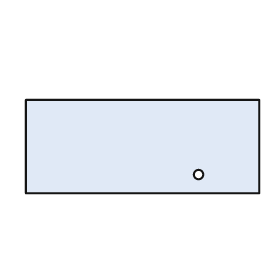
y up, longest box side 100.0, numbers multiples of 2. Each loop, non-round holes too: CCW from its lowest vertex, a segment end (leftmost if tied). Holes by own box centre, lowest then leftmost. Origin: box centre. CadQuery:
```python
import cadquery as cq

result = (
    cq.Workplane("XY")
    .moveTo(-50.0, -20.0)
    .lineTo(50.0, -20.0)
    .lineTo(50.0, 20.0)
    .lineTo(-50.0, 20.0)
    .close()
    .moveTo(24.0, -12.0)
    .circle(2.0)
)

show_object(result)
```